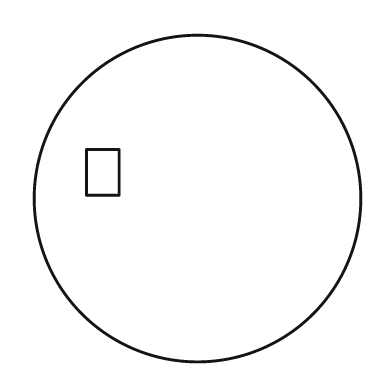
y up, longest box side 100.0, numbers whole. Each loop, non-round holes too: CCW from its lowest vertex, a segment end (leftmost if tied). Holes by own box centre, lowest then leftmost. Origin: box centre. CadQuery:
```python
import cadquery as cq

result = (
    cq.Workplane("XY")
    .moveTo(0.0, 0.0)
    .circle(50.0)
    .moveTo(-34.0, 1.0)
    .lineTo(-24.0, 1.0)
    .lineTo(-24.0, 15.0)
    .lineTo(-34.0, 15.0)
    .close()
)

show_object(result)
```